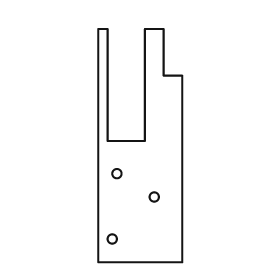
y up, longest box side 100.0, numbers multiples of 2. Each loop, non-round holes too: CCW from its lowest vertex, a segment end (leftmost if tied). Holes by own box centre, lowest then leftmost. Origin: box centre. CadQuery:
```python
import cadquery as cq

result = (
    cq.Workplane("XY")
    .moveTo(-18.0, -50.0)
    .lineTo(18.0, -50.0)
    .lineTo(18.0, 30.0)
    .lineTo(10.0, 30.0)
    .lineTo(10.0, 50.0)
    .lineTo(2.0, 50.0)
    .lineTo(2.0, 2.0)
    .lineTo(-14.0, 2.0)
    .lineTo(-14.0, 50.0)
    .lineTo(-18.0, 50.0)
    .close()
    .moveTo(-12.0, -40.0)
    .circle(2.0)
    .moveTo(6.0, -22.0)
    .circle(2.0)
    .moveTo(-10.0, -12.0)
    .circle(2.0)
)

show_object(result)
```